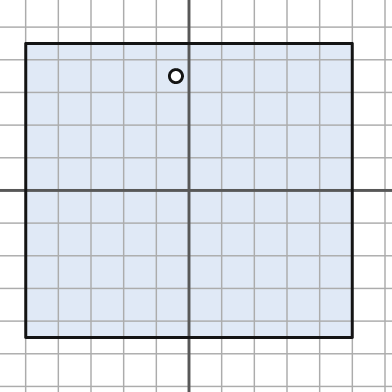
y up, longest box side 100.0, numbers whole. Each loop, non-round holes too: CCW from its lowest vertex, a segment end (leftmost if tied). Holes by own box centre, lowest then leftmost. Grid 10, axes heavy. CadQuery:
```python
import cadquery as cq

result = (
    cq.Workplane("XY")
    .moveTo(-50.0, -45.0)
    .lineTo(50.0, -45.0)
    .lineTo(50.0, 45.0)
    .lineTo(-50.0, 45.0)
    .close()
    .moveTo(-4.0, 35.0)
    .circle(2.0)
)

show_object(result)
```